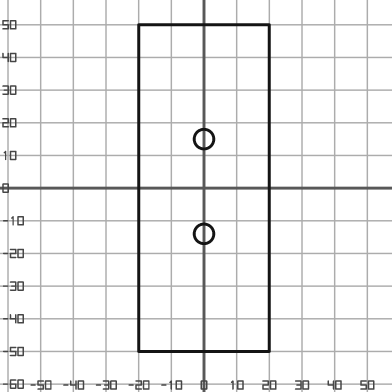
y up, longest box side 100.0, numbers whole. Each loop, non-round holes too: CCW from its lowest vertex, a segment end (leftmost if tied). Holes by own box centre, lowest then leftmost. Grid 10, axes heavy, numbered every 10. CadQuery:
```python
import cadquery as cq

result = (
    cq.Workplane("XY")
    .moveTo(-20.0, -50.0)
    .lineTo(20.0, -50.0)
    .lineTo(20.0, 50.0)
    .lineTo(-20.0, 50.0)
    .close()
    .moveTo(0.0, -14.0)
    .circle(3.0)
    .moveTo(0.0, 15.0)
    .circle(3.0)
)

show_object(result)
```